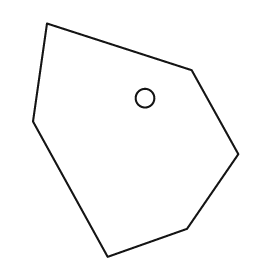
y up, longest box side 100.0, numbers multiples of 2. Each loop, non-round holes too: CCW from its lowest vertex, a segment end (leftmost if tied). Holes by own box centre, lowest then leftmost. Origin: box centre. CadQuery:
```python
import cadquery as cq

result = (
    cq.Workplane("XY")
    .moveTo(-12.0, -50.0)
    .lineTo(22.0, -38.0)
    .lineTo(44.0, -6.0)
    .lineTo(24.0, 30.0)
    .lineTo(-38.0, 50.0)
    .lineTo(-44.0, 8.0)
    .close()
    .moveTo(4.0, 18.0)
    .circle(4.0)
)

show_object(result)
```